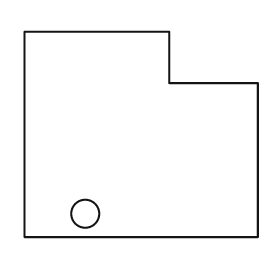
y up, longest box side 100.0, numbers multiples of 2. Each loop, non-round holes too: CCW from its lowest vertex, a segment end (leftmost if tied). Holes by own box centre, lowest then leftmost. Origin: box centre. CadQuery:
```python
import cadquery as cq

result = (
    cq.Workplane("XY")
    .moveTo(-50.0, -44.0)
    .lineTo(50.0, -44.0)
    .lineTo(50.0, 22.0)
    .lineTo(12.0, 22.0)
    .lineTo(12.0, 44.0)
    .lineTo(-50.0, 44.0)
    .close()
    .moveTo(-24.0, -34.0)
    .circle(6.0)
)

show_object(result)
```